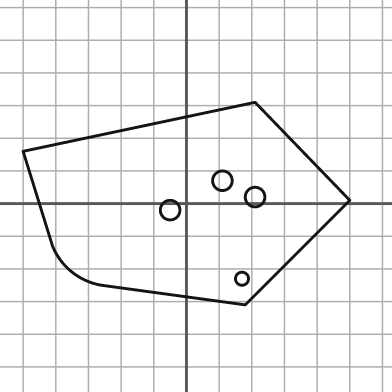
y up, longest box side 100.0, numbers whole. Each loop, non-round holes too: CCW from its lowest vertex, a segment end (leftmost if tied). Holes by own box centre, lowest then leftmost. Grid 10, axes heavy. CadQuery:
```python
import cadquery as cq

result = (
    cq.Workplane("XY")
    .moveTo(18.0, -31.0)
    .lineTo(50.0, 1.0)
    .lineTo(21.0, 31.0)
    .lineTo(-50.0, 16.0)
    .lineTo(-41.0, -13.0)
    .threePointArc((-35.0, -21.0), (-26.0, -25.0))
    .close()
    .moveTo(17.0, -23.0)
    .circle(2.0)
    .moveTo(-5.0, -2.0)
    .circle(3.0)
    .moveTo(21.0, 2.0)
    .circle(3.0)
    .moveTo(11.0, 7.0)
    .circle(3.0)
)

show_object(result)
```